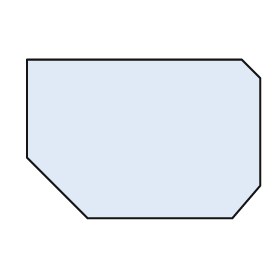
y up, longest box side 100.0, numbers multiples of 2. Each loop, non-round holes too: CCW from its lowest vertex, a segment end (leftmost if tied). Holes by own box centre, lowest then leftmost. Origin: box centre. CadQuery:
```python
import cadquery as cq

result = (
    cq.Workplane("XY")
    .moveTo(-24.0, -34.0)
    .lineTo(38.0, -34.0)
    .lineTo(50.0, -20.0)
    .lineTo(50.0, 26.0)
    .lineTo(42.0, 34.0)
    .lineTo(-50.0, 34.0)
    .lineTo(-50.0, -8.0)
    .close()
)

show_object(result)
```